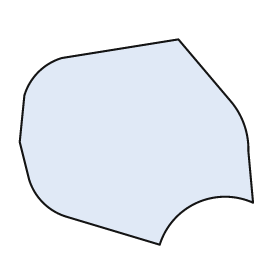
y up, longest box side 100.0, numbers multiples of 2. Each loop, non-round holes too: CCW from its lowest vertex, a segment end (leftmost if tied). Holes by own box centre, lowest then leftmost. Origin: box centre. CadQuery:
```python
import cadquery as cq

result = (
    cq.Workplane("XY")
    .moveTo(10.0, -44.0)
    .threePointArc((26.0, -26.0), (50.0, -26.0))
    .lineTo(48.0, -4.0)
    .threePointArc((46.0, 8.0), (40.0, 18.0))
    .lineTo(18.0, 44.0)
    .lineTo(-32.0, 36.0)
    .threePointArc((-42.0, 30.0), (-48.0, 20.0))
    .lineTo(-50.0, 0.0)
    .lineTo(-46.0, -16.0)
    .threePointArc((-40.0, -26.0), (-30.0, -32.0))
    .close()
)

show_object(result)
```